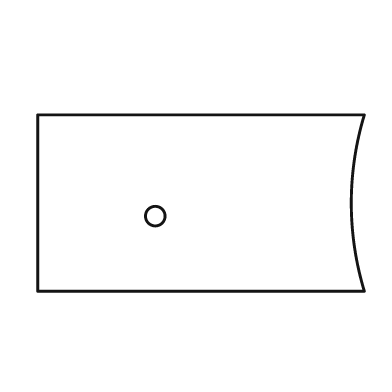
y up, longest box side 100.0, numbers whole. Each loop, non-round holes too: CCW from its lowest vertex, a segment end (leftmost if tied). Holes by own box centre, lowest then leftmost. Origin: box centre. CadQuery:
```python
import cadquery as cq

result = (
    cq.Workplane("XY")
    .moveTo(-50.0, -27.0)
    .lineTo(50.0, -27.0)
    .threePointArc((46.0, 0.0), (50.0, 27.0))
    .lineTo(-50.0, 27.0)
    .close()
    .moveTo(-14.0, -4.0)
    .circle(3.0)
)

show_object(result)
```